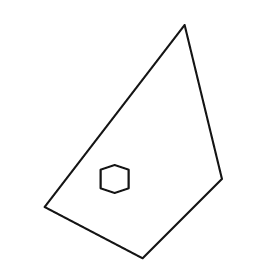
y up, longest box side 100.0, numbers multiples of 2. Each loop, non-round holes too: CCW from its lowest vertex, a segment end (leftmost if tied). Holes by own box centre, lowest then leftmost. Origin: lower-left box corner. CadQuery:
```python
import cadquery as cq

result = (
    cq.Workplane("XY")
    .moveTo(42.0, 0.0)
    .lineTo(76.0, 34.0)
    .lineTo(60.0, 100.0)
    .lineTo(0.0, 22.0)
    .close()
    .moveTo(30.0, 28.0)
    .lineTo(36.0, 30.0)
    .lineTo(36.0, 38.0)
    .lineTo(30.0, 40.0)
    .lineTo(24.0, 38.0)
    .lineTo(24.0, 30.0)
    .close()
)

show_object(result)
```